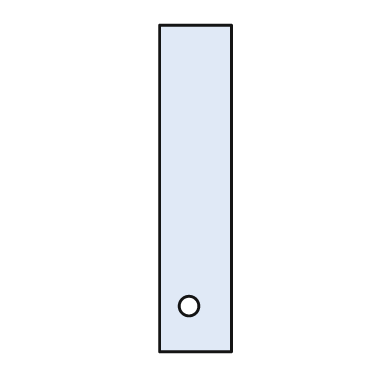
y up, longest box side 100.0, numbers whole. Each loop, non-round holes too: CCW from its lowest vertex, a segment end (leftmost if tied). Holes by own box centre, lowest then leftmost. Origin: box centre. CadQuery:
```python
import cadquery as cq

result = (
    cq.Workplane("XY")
    .moveTo(-11.0, -50.0)
    .lineTo(11.0, -50.0)
    .lineTo(11.0, 50.0)
    .lineTo(-11.0, 50.0)
    .close()
    .moveTo(-2.0, -36.0)
    .circle(3.0)
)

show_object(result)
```